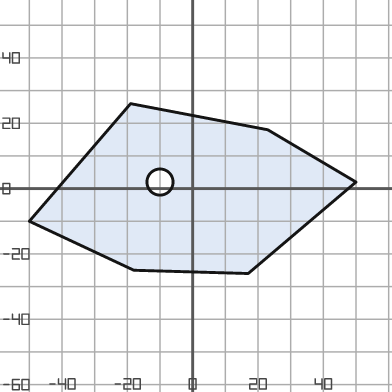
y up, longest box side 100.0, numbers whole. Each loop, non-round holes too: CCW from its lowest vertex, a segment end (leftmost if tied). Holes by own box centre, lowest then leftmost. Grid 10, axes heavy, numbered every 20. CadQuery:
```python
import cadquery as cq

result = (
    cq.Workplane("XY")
    .moveTo(17.0, -26.0)
    .lineTo(50.0, 2.0)
    .lineTo(23.0, 18.0)
    .lineTo(-19.0, 26.0)
    .lineTo(-50.0, -10.0)
    .lineTo(-18.0, -25.0)
    .close()
    .moveTo(-10.0, 2.0)
    .circle(4.0)
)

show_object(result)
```